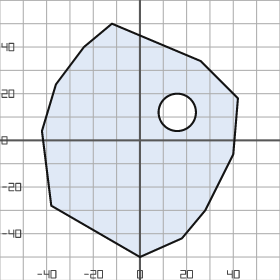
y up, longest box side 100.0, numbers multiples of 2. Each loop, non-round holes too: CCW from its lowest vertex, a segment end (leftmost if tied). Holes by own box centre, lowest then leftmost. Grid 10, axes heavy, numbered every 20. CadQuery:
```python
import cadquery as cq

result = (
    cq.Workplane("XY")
    .moveTo(0.0, -50.0)
    .lineTo(18.0, -42.0)
    .lineTo(28.0, -30.0)
    .lineTo(40.0, -6.0)
    .lineTo(42.0, 18.0)
    .lineTo(26.0, 34.0)
    .lineTo(-12.0, 50.0)
    .lineTo(-24.0, 40.0)
    .lineTo(-36.0, 24.0)
    .lineTo(-42.0, 4.0)
    .lineTo(-38.0, -28.0)
    .close()
    .moveTo(16.0, 12.0)
    .circle(8.0)
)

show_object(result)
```